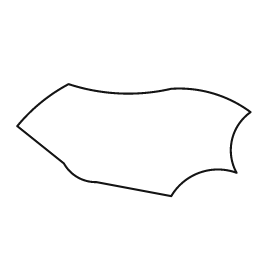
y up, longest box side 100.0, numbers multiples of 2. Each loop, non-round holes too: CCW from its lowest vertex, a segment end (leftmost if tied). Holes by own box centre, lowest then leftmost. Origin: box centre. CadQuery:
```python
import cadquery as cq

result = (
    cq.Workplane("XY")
    .moveTo(16.0, -24.0)
    .threePointArc((28.0, -14.0), (44.0, -14.0))
    .threePointArc((42.0, 0.0), (50.0, 12.0))
    .threePointArc((34.0, 20.0), (16.0, 22.0))
    .threePointArc((-6.0, 20.0), (-28.0, 24.0))
    .threePointArc((-40.0, 16.0), (-50.0, 6.0))
    .lineTo(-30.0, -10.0)
    .threePointArc((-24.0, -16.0), (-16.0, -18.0))
    .close()
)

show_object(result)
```